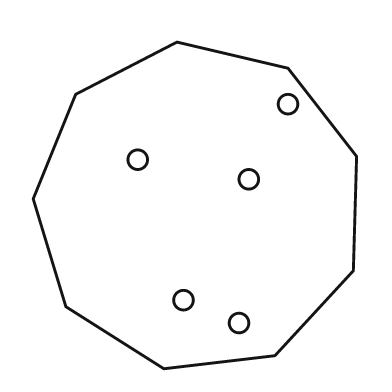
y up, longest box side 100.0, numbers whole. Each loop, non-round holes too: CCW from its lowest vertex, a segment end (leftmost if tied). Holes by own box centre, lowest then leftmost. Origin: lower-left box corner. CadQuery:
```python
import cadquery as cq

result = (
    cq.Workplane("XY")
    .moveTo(40.0, 0.0)
    .lineTo(74.0, 4.0)
    .lineTo(98.0, 30.0)
    .lineTo(99.0, 65.0)
    .lineTo(78.0, 92.0)
    .lineTo(44.0, 100.0)
    .lineTo(13.0, 84.0)
    .lineTo(0.0, 52.0)
    .lineTo(10.0, 19.0)
    .close()
    .moveTo(63.0, 14.0)
    .circle(3.0)
    .moveTo(46.0, 21.0)
    .circle(3.0)
    .moveTo(66.0, 58.0)
    .circle(3.0)
    .moveTo(32.0, 64.0)
    .circle(3.0)
    .moveTo(78.0, 81.0)
    .circle(3.0)
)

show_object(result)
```